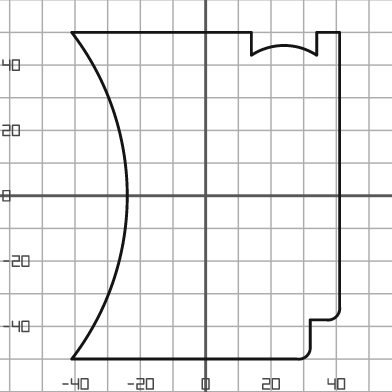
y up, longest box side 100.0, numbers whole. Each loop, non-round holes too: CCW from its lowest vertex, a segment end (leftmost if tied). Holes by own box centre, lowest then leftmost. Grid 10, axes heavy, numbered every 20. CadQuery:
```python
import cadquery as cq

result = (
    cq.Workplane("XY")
    .moveTo(-41.0, -50.0)
    .lineTo(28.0, -50.0)
    .threePointArc((31.0, -49.0), (32.0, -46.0))
    .lineTo(32.0, -38.0)
    .lineTo(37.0, -38.0)
    .threePointArc((40.0, -37.0), (41.0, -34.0))
    .lineTo(41.0, 50.0)
    .lineTo(34.0, 50.0)
    .lineTo(34.0, 43.0)
    .threePointArc((24.0, 46.0), (14.0, 43.0))
    .lineTo(14.0, 50.0)
    .lineTo(-41.0, 50.0)
    .threePointArc((-24.0, 0.0), (-41.0, -50.0))
    .close()
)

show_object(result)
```